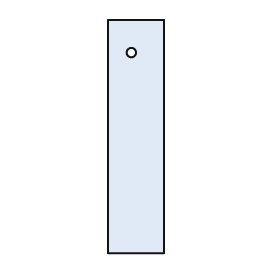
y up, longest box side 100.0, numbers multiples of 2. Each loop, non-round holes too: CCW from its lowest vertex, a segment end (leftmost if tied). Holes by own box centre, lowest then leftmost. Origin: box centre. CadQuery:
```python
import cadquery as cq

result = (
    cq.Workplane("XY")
    .moveTo(-12.0, -50.0)
    .lineTo(12.0, -50.0)
    .lineTo(12.0, 50.0)
    .lineTo(-12.0, 50.0)
    .close()
    .moveTo(-2.0, 36.0)
    .circle(2.0)
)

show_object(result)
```